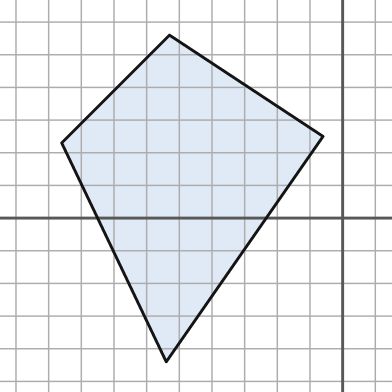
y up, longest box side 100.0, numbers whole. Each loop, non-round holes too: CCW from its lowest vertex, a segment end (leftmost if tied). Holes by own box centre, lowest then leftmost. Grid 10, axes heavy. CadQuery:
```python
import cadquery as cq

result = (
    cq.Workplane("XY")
    .moveTo(-54.0, -44.0)
    .lineTo(-6.0, 25.0)
    .lineTo(-53.0, 56.0)
    .lineTo(-86.0, 23.0)
    .close()
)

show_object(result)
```